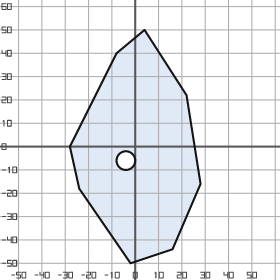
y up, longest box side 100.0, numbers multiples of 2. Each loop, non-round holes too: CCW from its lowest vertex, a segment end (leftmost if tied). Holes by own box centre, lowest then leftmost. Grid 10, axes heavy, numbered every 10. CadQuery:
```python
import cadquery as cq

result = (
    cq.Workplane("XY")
    .moveTo(-2.0, -50.0)
    .lineTo(16.0, -44.0)
    .lineTo(28.0, -16.0)
    .lineTo(22.0, 22.0)
    .lineTo(4.0, 50.0)
    .lineTo(-8.0, 40.0)
    .lineTo(-28.0, 0.0)
    .lineTo(-24.0, -18.0)
    .close()
    .moveTo(-4.0, -6.0)
    .circle(4.0)
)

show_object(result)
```